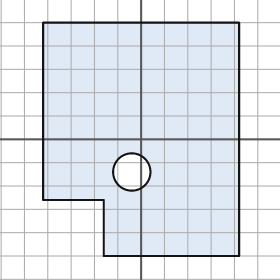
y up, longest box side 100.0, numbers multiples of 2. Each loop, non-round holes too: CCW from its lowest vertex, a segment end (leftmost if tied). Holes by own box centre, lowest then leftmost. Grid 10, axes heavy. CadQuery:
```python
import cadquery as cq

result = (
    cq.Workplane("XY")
    .moveTo(-16.0, -50.0)
    .lineTo(42.0, -50.0)
    .lineTo(42.0, 50.0)
    .lineTo(-42.0, 50.0)
    .lineTo(-42.0, -26.0)
    .lineTo(-16.0, -26.0)
    .close()
    .moveTo(-4.0, -14.0)
    .circle(8.0)
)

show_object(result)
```